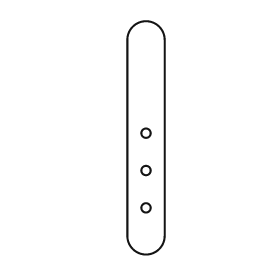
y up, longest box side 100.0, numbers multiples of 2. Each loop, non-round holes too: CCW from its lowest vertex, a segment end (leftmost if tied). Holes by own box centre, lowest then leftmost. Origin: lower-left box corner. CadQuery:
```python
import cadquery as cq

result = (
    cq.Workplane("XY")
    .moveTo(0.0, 8.0)
    .threePointArc((8.0, 0.0), (16.0, 8.0))
    .lineTo(16.0, 92.0)
    .threePointArc((8.0, 100.0), (0.0, 92.0))
    .close()
    .moveTo(8.0, 20.0)
    .circle(2.0)
    .moveTo(8.0, 36.0)
    .circle(2.0)
    .moveTo(8.0, 52.0)
    .circle(2.0)
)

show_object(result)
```